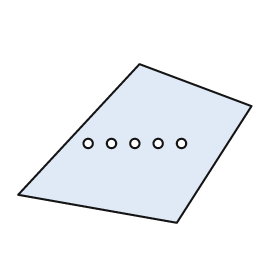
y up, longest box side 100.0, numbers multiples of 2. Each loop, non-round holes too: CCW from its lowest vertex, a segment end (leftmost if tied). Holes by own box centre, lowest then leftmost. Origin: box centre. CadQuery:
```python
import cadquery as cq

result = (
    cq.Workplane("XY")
    .moveTo(18.0, -34.0)
    .lineTo(50.0, 16.0)
    .lineTo(2.0, 34.0)
    .lineTo(-50.0, -22.0)
    .close()
    .moveTo(-20.0, 0.0)
    .circle(2.0)
    .moveTo(-10.0, 0.0)
    .circle(2.0)
    .moveTo(0.0, 0.0)
    .circle(2.0)
    .moveTo(10.0, 0.0)
    .circle(2.0)
    .moveTo(20.0, 0.0)
    .circle(2.0)
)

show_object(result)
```